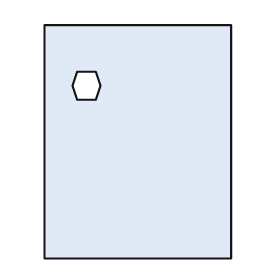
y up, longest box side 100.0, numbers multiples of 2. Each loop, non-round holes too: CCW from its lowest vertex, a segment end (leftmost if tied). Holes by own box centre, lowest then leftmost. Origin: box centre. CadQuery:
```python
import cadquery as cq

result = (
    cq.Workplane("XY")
    .moveTo(-40.0, -50.0)
    .lineTo(40.0, -50.0)
    .lineTo(40.0, 50.0)
    .lineTo(-40.0, 50.0)
    .close()
    .moveTo(-26.0, 18.0)
    .lineTo(-18.0, 18.0)
    .lineTo(-16.0, 24.0)
    .lineTo(-18.0, 30.0)
    .lineTo(-26.0, 30.0)
    .lineTo(-28.0, 24.0)
    .close()
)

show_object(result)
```